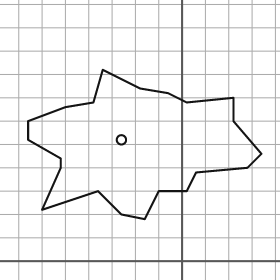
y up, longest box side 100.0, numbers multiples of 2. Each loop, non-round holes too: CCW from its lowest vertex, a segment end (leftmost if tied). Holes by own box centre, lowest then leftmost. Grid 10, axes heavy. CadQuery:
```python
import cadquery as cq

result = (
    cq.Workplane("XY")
    .moveTo(-16.0, 18.0)
    .lineTo(-10.0, 30.0)
    .lineTo(2.0, 30.0)
    .lineTo(6.0, 38.0)
    .lineTo(28.0, 40.0)
    .lineTo(34.0, 46.0)
    .lineTo(22.0, 60.0)
    .lineTo(22.0, 70.0)
    .lineTo(2.0, 68.0)
    .lineTo(-6.0, 72.0)
    .lineTo(-18.0, 74.0)
    .lineTo(-34.0, 82.0)
    .lineTo(-38.0, 68.0)
    .lineTo(-50.0, 66.0)
    .lineTo(-66.0, 60.0)
    .lineTo(-66.0, 52.0)
    .lineTo(-52.0, 44.0)
    .lineTo(-52.0, 40.0)
    .lineTo(-60.0, 22.0)
    .lineTo(-36.0, 30.0)
    .lineTo(-26.0, 20.0)
    .close()
    .moveTo(-26.0, 52.0)
    .circle(2.0)
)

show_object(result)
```